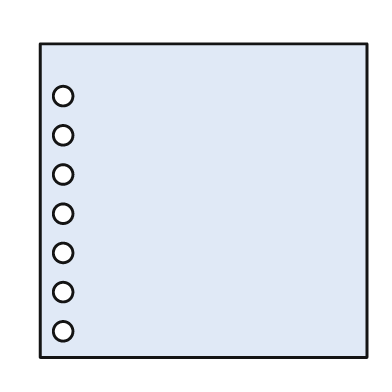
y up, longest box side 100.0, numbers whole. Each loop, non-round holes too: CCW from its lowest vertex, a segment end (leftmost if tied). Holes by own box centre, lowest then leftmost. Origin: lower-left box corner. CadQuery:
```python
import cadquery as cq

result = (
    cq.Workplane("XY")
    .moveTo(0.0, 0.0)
    .lineTo(100.0, 0.0)
    .lineTo(100.0, 96.0)
    .lineTo(0.0, 96.0)
    .close()
    .moveTo(7.0, 8.0)
    .circle(3.0)
    .moveTo(7.0, 20.0)
    .circle(3.0)
    .moveTo(7.0, 32.0)
    .circle(3.0)
    .moveTo(7.0, 44.0)
    .circle(3.0)
    .moveTo(7.0, 56.0)
    .circle(3.0)
    .moveTo(7.0, 68.0)
    .circle(3.0)
    .moveTo(7.0, 80.0)
    .circle(3.0)
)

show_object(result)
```